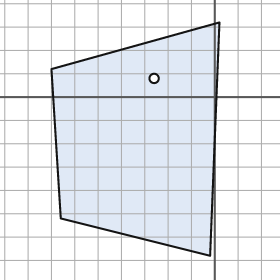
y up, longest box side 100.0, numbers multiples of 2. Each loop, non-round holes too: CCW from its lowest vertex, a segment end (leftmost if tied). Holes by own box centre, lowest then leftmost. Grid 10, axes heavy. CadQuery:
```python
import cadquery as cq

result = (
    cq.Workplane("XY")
    .moveTo(-2.0, -68.0)
    .lineTo(2.0, 32.0)
    .lineTo(-70.0, 12.0)
    .lineTo(-66.0, -52.0)
    .close()
    .moveTo(-26.0, 8.0)
    .circle(2.0)
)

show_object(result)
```